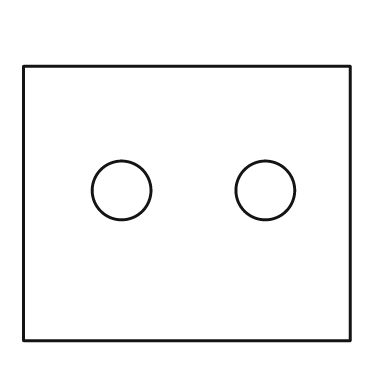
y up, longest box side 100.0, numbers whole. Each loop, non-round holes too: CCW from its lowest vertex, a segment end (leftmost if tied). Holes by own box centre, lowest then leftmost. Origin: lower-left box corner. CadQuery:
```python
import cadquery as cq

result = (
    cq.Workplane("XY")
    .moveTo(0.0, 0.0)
    .lineTo(100.0, 0.0)
    .lineTo(100.0, 84.0)
    .lineTo(0.0, 84.0)
    .close()
    .moveTo(30.0, 46.0)
    .circle(9.0)
    .moveTo(74.0, 46.0)
    .circle(9.0)
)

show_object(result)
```